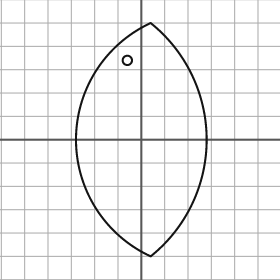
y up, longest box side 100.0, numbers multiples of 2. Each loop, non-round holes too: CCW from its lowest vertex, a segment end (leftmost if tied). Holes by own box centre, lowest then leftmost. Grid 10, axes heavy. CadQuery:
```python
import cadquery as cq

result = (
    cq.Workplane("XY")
    .moveTo(4.0, -50.0)
    .threePointArc((28.0, 0.0), (4.0, 50.0))
    .threePointArc((-28.0, 0.0), (4.0, -50.0))
    .close()
    .moveTo(-6.0, 34.0)
    .circle(2.0)
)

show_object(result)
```